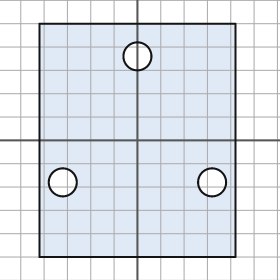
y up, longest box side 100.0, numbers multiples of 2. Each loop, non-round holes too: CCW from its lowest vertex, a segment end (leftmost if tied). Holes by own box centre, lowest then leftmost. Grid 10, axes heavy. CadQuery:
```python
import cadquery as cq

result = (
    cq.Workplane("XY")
    .moveTo(-42.0, -50.0)
    .lineTo(42.0, -50.0)
    .lineTo(42.0, 50.0)
    .lineTo(-42.0, 50.0)
    .close()
    .moveTo(-32.0, -18.0)
    .circle(6.0)
    .moveTo(32.0, -18.0)
    .circle(6.0)
    .moveTo(0.0, 36.0)
    .circle(6.0)
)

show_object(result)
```